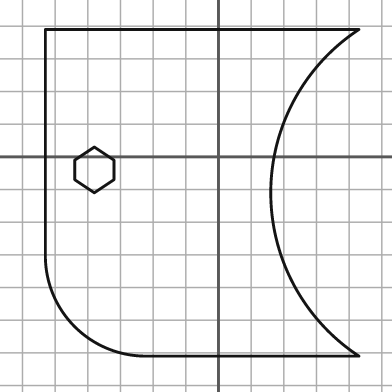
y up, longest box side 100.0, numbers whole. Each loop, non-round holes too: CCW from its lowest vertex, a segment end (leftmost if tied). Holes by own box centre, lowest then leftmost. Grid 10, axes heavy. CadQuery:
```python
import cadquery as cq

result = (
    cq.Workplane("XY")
    .moveTo(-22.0, -61.0)
    .lineTo(43.0, -61.0)
    .threePointArc((16.0, -11.0), (43.0, 39.0))
    .lineTo(-53.0, 39.0)
    .lineTo(-53.0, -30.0)
    .threePointArc((-44.0, -52.0), (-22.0, -61.0))
    .close()
    .moveTo(-38.0, -11.0)
    .lineTo(-32.0, -7.0)
    .lineTo(-32.0, -1.0)
    .lineTo(-38.0, 3.0)
    .lineTo(-44.0, -1.0)
    .lineTo(-44.0, -7.0)
    .close()
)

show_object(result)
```